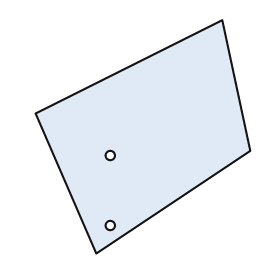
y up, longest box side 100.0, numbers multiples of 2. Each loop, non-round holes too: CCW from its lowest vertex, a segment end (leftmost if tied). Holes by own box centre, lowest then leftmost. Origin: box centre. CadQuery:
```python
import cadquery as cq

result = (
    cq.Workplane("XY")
    .moveTo(-20.0, -50.0)
    .lineTo(46.0, -6.0)
    .lineTo(34.0, 50.0)
    .lineTo(-46.0, 10.0)
    .close()
    .moveTo(-14.0, -38.0)
    .circle(2.0)
    .moveTo(-14.0, -8.0)
    .circle(2.0)
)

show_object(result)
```